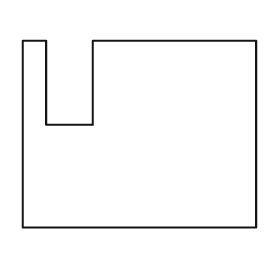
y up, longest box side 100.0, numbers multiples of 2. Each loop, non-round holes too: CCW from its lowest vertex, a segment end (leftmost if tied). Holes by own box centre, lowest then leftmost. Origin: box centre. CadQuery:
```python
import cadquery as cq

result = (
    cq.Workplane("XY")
    .moveTo(-50.0, -40.0)
    .lineTo(50.0, -40.0)
    .lineTo(50.0, 40.0)
    .lineTo(-20.0, 40.0)
    .lineTo(-20.0, 4.0)
    .lineTo(-40.0, 4.0)
    .lineTo(-40.0, 40.0)
    .lineTo(-50.0, 40.0)
    .close()
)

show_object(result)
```